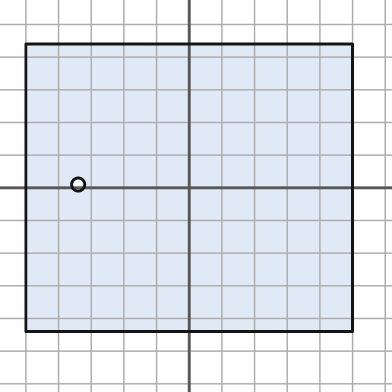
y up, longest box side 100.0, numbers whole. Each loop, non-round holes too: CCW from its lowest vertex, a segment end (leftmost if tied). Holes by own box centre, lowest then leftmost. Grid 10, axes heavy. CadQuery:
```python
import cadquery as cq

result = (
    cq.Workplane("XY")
    .moveTo(-50.0, -44.0)
    .lineTo(50.0, -44.0)
    .lineTo(50.0, 44.0)
    .lineTo(-50.0, 44.0)
    .close()
    .moveTo(-34.0, 1.0)
    .circle(2.0)
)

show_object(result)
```